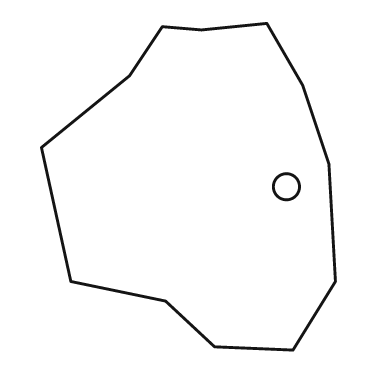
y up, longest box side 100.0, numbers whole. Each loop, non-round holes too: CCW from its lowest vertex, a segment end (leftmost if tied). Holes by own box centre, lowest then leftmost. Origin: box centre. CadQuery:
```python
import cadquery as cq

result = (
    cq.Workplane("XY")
    .moveTo(32.0, -50.0)
    .lineTo(45.0, -29.0)
    .lineTo(43.0, 7.0)
    .lineTo(35.0, 31.0)
    .lineTo(24.0, 50.0)
    .lineTo(4.0, 48.0)
    .lineTo(-8.0, 49.0)
    .lineTo(-18.0, 34.0)
    .lineTo(-45.0, 12.0)
    .lineTo(-36.0, -29.0)
    .lineTo(-7.0, -35.0)
    .lineTo(8.0, -49.0)
    .close()
    .moveTo(30.0, 0.0)
    .circle(4.0)
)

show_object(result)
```